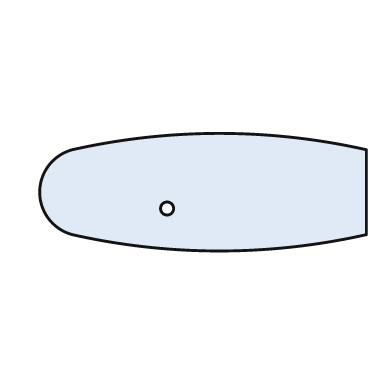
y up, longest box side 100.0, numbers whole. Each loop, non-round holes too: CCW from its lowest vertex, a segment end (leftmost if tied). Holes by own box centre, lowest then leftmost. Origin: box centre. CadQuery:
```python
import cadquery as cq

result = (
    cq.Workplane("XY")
    .moveTo(-40.0, -13.0)
    .threePointArc((5.0, -18.0), (50.0, -13.0))
    .lineTo(50.0, 13.0)
    .threePointArc((5.0, 18.0), (-40.0, 13.0))
    .threePointArc((-50.0, 0.0), (-40.0, -13.0))
    .close()
    .moveTo(-11.0, -5.0)
    .circle(2.0)
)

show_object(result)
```